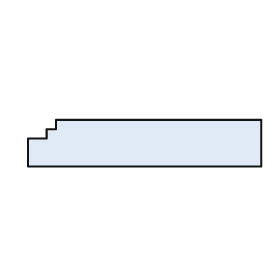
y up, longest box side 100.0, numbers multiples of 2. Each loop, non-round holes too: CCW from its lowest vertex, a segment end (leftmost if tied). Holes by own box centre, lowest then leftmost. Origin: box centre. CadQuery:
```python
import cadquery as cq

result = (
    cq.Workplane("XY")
    .moveTo(-50.0, -10.0)
    .lineTo(50.0, -10.0)
    .lineTo(50.0, 10.0)
    .lineTo(-38.0, 10.0)
    .lineTo(-38.0, 6.0)
    .lineTo(-42.0, 6.0)
    .lineTo(-42.0, 2.0)
    .lineTo(-50.0, 2.0)
    .close()
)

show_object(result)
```